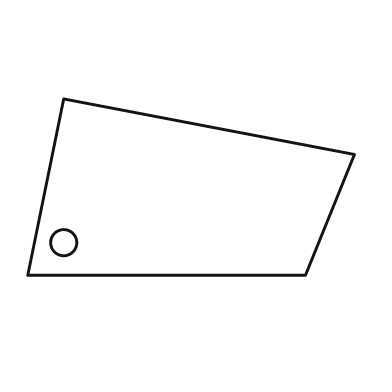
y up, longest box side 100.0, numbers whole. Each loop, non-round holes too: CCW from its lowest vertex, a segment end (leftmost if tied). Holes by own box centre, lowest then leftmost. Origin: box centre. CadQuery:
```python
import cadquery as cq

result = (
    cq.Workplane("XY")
    .moveTo(-50.0, -27.0)
    .lineTo(35.0, -27.0)
    .lineTo(50.0, 10.0)
    .lineTo(-39.0, 27.0)
    .close()
    .moveTo(-39.0, -17.0)
    .circle(4.0)
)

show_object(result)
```